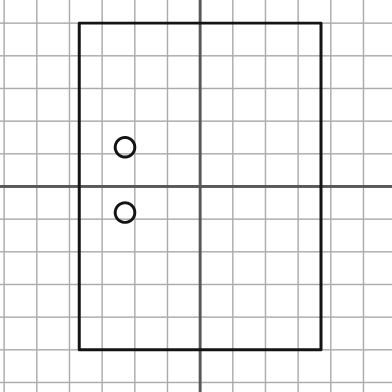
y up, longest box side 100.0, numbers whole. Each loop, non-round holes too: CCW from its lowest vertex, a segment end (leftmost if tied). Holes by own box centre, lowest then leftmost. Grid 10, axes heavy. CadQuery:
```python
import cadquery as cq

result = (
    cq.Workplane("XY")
    .moveTo(-37.0, -50.0)
    .lineTo(37.0, -50.0)
    .lineTo(37.0, 50.0)
    .lineTo(-37.0, 50.0)
    .close()
    .moveTo(-23.0, -8.0)
    .circle(3.0)
    .moveTo(-23.0, 12.0)
    .circle(3.0)
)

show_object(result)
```